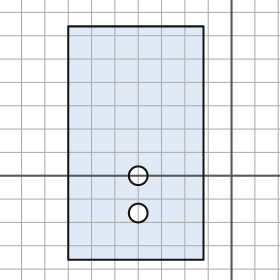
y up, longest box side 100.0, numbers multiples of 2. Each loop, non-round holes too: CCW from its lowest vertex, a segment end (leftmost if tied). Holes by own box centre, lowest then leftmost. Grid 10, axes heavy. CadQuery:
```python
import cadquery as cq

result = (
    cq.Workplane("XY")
    .moveTo(-70.0, -36.0)
    .lineTo(-12.0, -36.0)
    .lineTo(-12.0, 64.0)
    .lineTo(-70.0, 64.0)
    .close()
    .moveTo(-40.0, -16.0)
    .circle(4.0)
    .moveTo(-40.0, 0.0)
    .circle(4.0)
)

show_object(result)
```